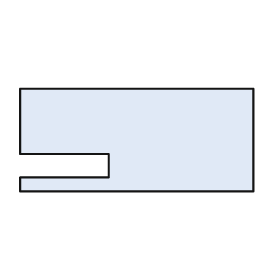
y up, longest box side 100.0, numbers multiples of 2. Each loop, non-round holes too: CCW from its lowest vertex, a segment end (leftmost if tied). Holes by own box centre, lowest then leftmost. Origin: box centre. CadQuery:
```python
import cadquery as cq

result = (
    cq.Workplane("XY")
    .moveTo(-50.0, -22.0)
    .lineTo(50.0, -22.0)
    .lineTo(50.0, 22.0)
    .lineTo(-50.0, 22.0)
    .lineTo(-50.0, -6.0)
    .lineTo(-12.0, -6.0)
    .lineTo(-12.0, -16.0)
    .lineTo(-50.0, -16.0)
    .close()
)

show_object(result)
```